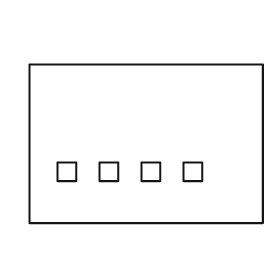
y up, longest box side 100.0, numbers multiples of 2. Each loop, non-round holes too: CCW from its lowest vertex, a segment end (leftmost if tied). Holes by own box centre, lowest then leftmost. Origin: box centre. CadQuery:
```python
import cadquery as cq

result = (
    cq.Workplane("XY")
    .moveTo(-50.0, -34.0)
    .lineTo(50.0, -34.0)
    .lineTo(50.0, 34.0)
    .lineTo(-50.0, 34.0)
    .close()
    .moveTo(-38.0, -16.0)
    .lineTo(-30.0, -16.0)
    .lineTo(-30.0, -8.0)
    .lineTo(-38.0, -8.0)
    .close()
    .moveTo(-20.0, -16.0)
    .lineTo(-12.0, -16.0)
    .lineTo(-12.0, -8.0)
    .lineTo(-20.0, -8.0)
    .close()
    .moveTo(-2.0, -16.0)
    .lineTo(6.0, -16.0)
    .lineTo(6.0, -8.0)
    .lineTo(-2.0, -8.0)
    .close()
    .moveTo(16.0, -16.0)
    .lineTo(24.0, -16.0)
    .lineTo(24.0, -8.0)
    .lineTo(16.0, -8.0)
    .close()
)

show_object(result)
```